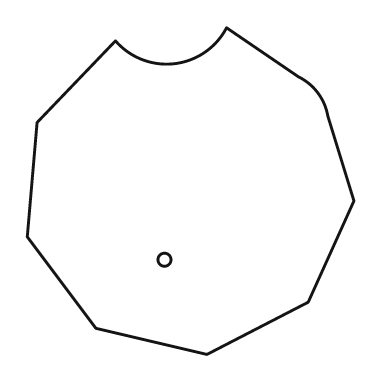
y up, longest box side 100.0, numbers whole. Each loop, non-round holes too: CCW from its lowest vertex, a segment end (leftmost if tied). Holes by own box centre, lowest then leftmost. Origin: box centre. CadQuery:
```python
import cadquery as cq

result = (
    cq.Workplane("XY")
    .moveTo(5.0, -50.0)
    .lineTo(36.0, -34.0)
    .lineTo(50.0, -3.0)
    .lineTo(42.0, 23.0)
    .threePointArc((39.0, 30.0), (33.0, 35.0))
    .lineTo(11.0, 50.0)
    .threePointArc((-5.0, 39.0), (-23.0, 46.0))
    .lineTo(-47.0, 21.0)
    .lineTo(-50.0, -14.0)
    .lineTo(-29.0, -42.0)
    .close()
    .moveTo(-8.0, -21.0)
    .circle(2.0)
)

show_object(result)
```